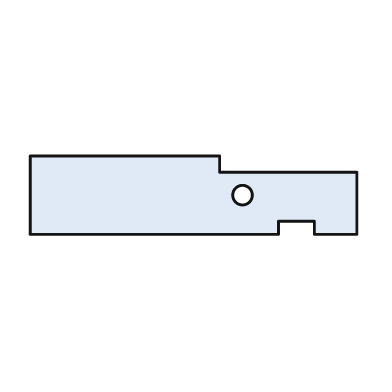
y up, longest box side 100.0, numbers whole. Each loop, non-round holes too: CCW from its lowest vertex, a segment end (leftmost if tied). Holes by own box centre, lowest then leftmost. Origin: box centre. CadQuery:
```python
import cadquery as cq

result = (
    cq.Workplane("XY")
    .moveTo(-50.0, -12.0)
    .lineTo(26.0, -12.0)
    .lineTo(26.0, -8.0)
    .lineTo(37.0, -8.0)
    .lineTo(37.0, -12.0)
    .lineTo(50.0, -12.0)
    .lineTo(50.0, 7.0)
    .lineTo(8.0, 7.0)
    .lineTo(8.0, 12.0)
    .lineTo(-50.0, 12.0)
    .close()
    .moveTo(15.0, 0.0)
    .circle(3.0)
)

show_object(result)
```